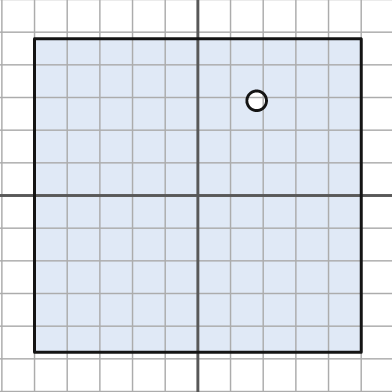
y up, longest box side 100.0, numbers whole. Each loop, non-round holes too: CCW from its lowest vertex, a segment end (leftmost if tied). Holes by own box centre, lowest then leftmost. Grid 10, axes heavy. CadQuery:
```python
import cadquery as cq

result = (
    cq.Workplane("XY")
    .moveTo(-50.0, -48.0)
    .lineTo(50.0, -48.0)
    .lineTo(50.0, 48.0)
    .lineTo(-50.0, 48.0)
    .close()
    .moveTo(18.0, 29.0)
    .circle(3.0)
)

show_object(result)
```